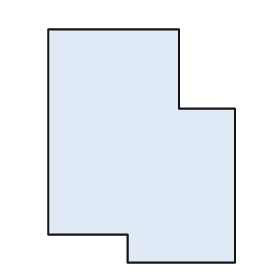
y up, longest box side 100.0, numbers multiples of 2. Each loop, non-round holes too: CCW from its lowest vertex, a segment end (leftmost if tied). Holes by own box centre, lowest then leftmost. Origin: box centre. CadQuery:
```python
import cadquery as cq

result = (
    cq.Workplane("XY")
    .moveTo(-6.0, -50.0)
    .lineTo(40.0, -50.0)
    .lineTo(40.0, 16.0)
    .lineTo(16.0, 16.0)
    .lineTo(16.0, 50.0)
    .lineTo(-40.0, 50.0)
    .lineTo(-40.0, -38.0)
    .lineTo(-6.0, -38.0)
    .close()
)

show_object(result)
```